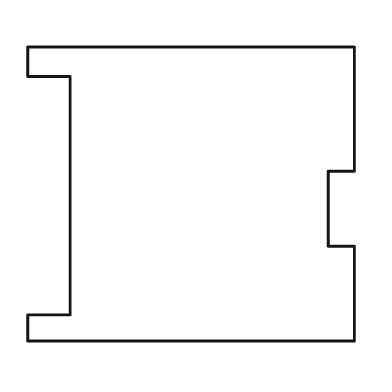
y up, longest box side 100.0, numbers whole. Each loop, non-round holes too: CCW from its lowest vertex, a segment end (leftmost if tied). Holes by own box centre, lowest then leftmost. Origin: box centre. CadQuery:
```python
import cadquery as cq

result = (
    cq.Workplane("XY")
    .moveTo(-50.0, -45.0)
    .lineTo(50.0, -45.0)
    .lineTo(50.0, -16.0)
    .lineTo(42.0, -16.0)
    .lineTo(42.0, 7.0)
    .lineTo(50.0, 7.0)
    .lineTo(50.0, 45.0)
    .lineTo(-50.0, 45.0)
    .lineTo(-50.0, 36.0)
    .lineTo(-37.0, 36.0)
    .lineTo(-37.0, -37.0)
    .lineTo(-50.0, -37.0)
    .close()
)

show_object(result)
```